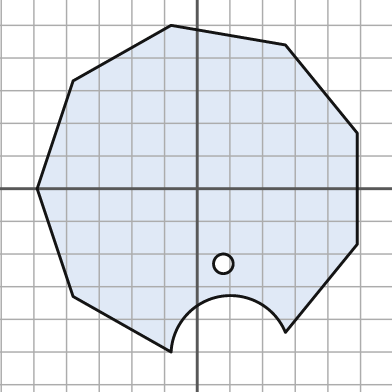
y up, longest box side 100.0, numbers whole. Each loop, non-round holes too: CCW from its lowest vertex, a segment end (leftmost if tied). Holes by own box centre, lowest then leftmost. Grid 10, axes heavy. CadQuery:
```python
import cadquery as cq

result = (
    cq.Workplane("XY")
    .moveTo(-8.0, -50.0)
    .threePointArc((7.0, -33.0), (27.0, -44.0))
    .lineTo(49.0, -17.0)
    .lineTo(49.0, 17.0)
    .lineTo(27.0, 44.0)
    .lineTo(-8.0, 50.0)
    .lineTo(-38.0, 33.0)
    .lineTo(-49.0, 0.0)
    .lineTo(-38.0, -33.0)
    .close()
    .moveTo(8.0, -23.0)
    .circle(3.0)
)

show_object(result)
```